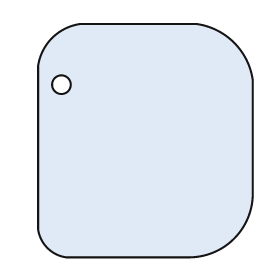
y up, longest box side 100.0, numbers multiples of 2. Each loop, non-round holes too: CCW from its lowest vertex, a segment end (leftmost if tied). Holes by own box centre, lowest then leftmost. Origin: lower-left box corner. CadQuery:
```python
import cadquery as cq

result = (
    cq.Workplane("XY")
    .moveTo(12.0, 0.0)
    .lineTo(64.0, 0.0)
    .threePointArc((84.0, 8.0), (92.0, 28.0))
    .lineTo(92.0, 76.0)
    .threePointArc((84.0, 92.0), (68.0, 100.0))
    .lineTo(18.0, 100.0)
    .threePointArc((6.0, 94.0), (0.0, 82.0))
    .lineTo(0.0, 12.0)
    .threePointArc((4.0, 4.0), (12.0, 0.0))
    .close()
    .moveTo(10.0, 74.0)
    .circle(4.0)
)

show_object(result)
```